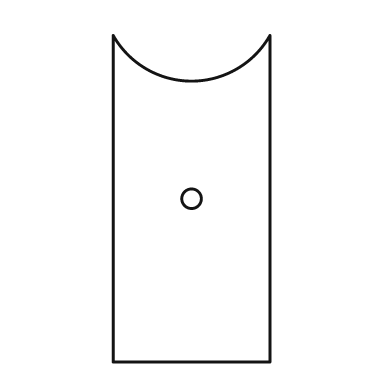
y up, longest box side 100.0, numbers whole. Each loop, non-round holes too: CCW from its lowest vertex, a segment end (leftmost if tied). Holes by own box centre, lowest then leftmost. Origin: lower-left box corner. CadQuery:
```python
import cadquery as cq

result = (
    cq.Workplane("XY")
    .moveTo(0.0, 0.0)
    .lineTo(48.0, 0.0)
    .lineTo(48.0, 100.0)
    .threePointArc((24.0, 86.0), (0.0, 100.0))
    .close()
    .moveTo(24.0, 50.0)
    .circle(3.0)
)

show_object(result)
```